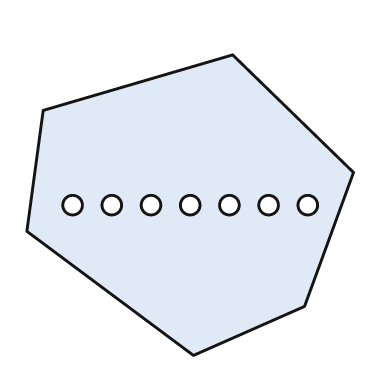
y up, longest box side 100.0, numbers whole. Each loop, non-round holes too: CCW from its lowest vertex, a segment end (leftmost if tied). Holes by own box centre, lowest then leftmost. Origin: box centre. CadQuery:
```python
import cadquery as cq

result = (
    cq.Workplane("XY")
    .moveTo(1.0, -46.0)
    .lineTo(35.0, -31.0)
    .lineTo(50.0, 10.0)
    .lineTo(13.0, 46.0)
    .lineTo(-45.0, 29.0)
    .lineTo(-50.0, -8.0)
    .close()
    .moveTo(-36.0, 0.0)
    .circle(3.0)
    .moveTo(-24.0, 0.0)
    .circle(3.0)
    .moveTo(-12.0, 0.0)
    .circle(3.0)
    .moveTo(0.0, 0.0)
    .circle(3.0)
    .moveTo(12.0, 0.0)
    .circle(3.0)
    .moveTo(24.0, 0.0)
    .circle(3.0)
    .moveTo(36.0, 0.0)
    .circle(3.0)
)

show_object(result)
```